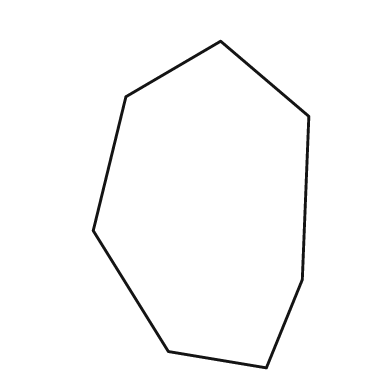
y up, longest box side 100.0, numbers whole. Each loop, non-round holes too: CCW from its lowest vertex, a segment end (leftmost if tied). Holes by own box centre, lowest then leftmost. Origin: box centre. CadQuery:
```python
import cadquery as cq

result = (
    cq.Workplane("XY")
    .moveTo(20.0, -50.0)
    .lineTo(31.0, -23.0)
    .lineTo(33.0, 27.0)
    .lineTo(6.0, 50.0)
    .lineTo(-23.0, 33.0)
    .lineTo(-33.0, -8.0)
    .lineTo(-10.0, -45.0)
    .close()
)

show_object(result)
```